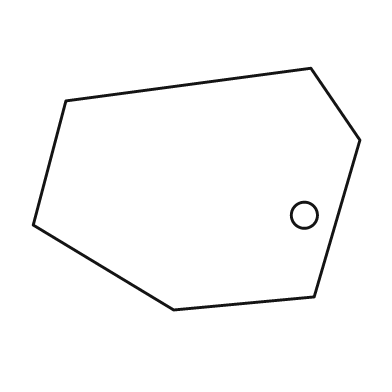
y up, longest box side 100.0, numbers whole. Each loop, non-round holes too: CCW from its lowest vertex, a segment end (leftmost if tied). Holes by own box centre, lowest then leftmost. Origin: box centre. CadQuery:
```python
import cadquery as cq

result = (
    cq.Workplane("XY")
    .moveTo(-7.0, -37.0)
    .lineTo(36.0, -33.0)
    .lineTo(50.0, 15.0)
    .lineTo(35.0, 37.0)
    .lineTo(-40.0, 27.0)
    .lineTo(-50.0, -11.0)
    .close()
    .moveTo(33.0, -8.0)
    .circle(4.0)
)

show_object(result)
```